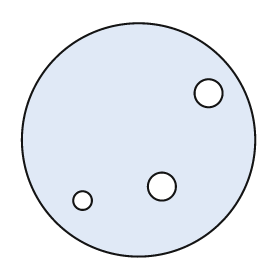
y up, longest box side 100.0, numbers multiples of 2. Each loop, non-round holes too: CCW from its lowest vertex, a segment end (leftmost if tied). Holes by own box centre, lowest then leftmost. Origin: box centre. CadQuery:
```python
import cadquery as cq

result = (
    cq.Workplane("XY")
    .moveTo(0.0, 0.0)
    .circle(50.0)
    .moveTo(-24.0, -26.0)
    .circle(4.0)
    .moveTo(10.0, -20.0)
    .circle(6.0)
    .moveTo(30.0, 20.0)
    .circle(6.0)
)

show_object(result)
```